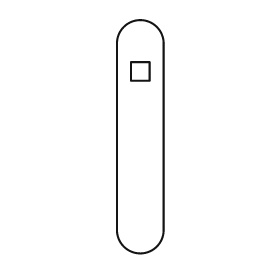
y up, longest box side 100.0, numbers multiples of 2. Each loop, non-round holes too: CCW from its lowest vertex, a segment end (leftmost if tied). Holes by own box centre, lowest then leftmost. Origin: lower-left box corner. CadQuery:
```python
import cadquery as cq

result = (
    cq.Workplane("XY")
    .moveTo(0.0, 10.0)
    .threePointArc((10.0, 0.0), (20.0, 10.0))
    .lineTo(20.0, 90.0)
    .threePointArc((10.0, 100.0), (0.0, 90.0))
    .close()
    .moveTo(6.0, 74.0)
    .lineTo(14.0, 74.0)
    .lineTo(14.0, 82.0)
    .lineTo(6.0, 82.0)
    .close()
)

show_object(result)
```